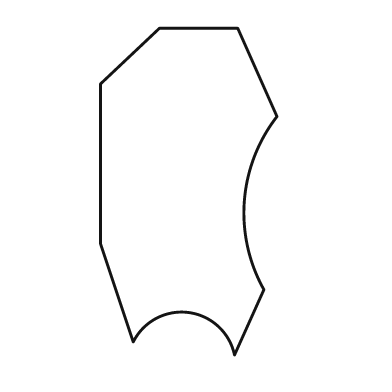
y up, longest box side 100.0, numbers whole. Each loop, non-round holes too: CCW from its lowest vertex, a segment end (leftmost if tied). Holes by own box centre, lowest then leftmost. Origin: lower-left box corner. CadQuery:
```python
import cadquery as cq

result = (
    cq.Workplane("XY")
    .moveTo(41.0, 0.0)
    .lineTo(50.0, 20.0)
    .threePointArc((44.0, 47.0), (54.0, 73.0))
    .lineTo(42.0, 100.0)
    .lineTo(18.0, 100.0)
    .lineTo(0.0, 83.0)
    .lineTo(0.0, 34.0)
    .lineTo(10.0, 4.0)
    .threePointArc((27.0, 13.0), (41.0, 0.0))
    .close()
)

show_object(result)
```